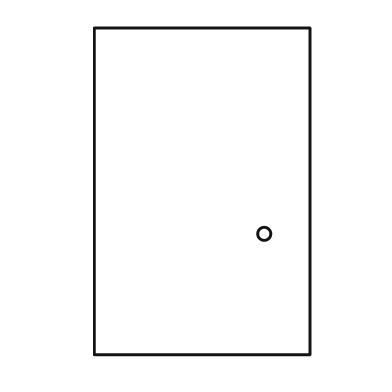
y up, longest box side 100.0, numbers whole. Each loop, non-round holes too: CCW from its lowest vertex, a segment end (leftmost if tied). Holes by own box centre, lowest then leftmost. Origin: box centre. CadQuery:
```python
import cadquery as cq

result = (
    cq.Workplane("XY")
    .moveTo(-33.0, -50.0)
    .lineTo(33.0, -50.0)
    .lineTo(33.0, 50.0)
    .lineTo(-33.0, 50.0)
    .close()
    .moveTo(19.0, -13.0)
    .circle(2.0)
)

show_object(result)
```